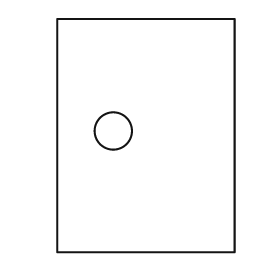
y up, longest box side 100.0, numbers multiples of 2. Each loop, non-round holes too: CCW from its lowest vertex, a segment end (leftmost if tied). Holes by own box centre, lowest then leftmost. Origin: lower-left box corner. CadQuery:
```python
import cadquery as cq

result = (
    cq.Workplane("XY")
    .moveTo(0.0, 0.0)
    .lineTo(76.0, 0.0)
    .lineTo(76.0, 100.0)
    .lineTo(0.0, 100.0)
    .close()
    .moveTo(24.0, 52.0)
    .circle(8.0)
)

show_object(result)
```